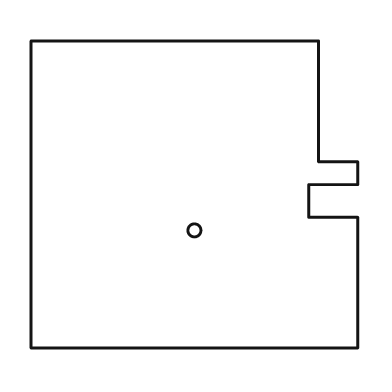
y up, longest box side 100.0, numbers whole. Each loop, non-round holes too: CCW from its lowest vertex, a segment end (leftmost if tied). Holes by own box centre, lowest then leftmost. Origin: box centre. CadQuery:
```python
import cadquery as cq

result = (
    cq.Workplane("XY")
    .moveTo(-50.0, -47.0)
    .lineTo(50.0, -47.0)
    .lineTo(50.0, -7.0)
    .lineTo(35.0, -7.0)
    .lineTo(35.0, 3.0)
    .lineTo(50.0, 3.0)
    .lineTo(50.0, 10.0)
    .lineTo(38.0, 10.0)
    .lineTo(38.0, 47.0)
    .lineTo(-50.0, 47.0)
    .close()
    .moveTo(0.0, -11.0)
    .circle(2.0)
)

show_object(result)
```